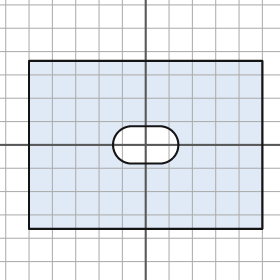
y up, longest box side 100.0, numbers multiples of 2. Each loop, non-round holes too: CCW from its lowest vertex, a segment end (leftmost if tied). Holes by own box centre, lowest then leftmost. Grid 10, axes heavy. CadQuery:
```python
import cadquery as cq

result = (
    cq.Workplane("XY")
    .moveTo(-50.0, -36.0)
    .lineTo(50.0, -36.0)
    .lineTo(50.0, 36.0)
    .lineTo(-50.0, 36.0)
    .close()
    .moveTo(-6.0, -8.0)
    .lineTo(6.0, -8.0)
    .threePointArc((14.0, 0.0), (6.0, 8.0))
    .lineTo(-6.0, 8.0)
    .threePointArc((-14.0, 0.0), (-6.0, -8.0))
    .close()
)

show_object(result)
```